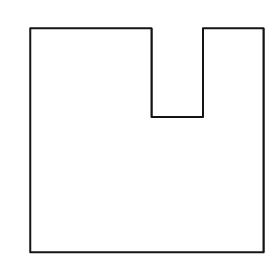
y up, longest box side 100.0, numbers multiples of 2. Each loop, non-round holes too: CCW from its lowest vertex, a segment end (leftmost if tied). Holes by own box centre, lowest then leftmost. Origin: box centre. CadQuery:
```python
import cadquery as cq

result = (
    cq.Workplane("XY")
    .moveTo(-50.0, -48.0)
    .lineTo(50.0, -48.0)
    .lineTo(50.0, 48.0)
    .lineTo(24.0, 48.0)
    .lineTo(24.0, 10.0)
    .lineTo(2.0, 10.0)
    .lineTo(2.0, 48.0)
    .lineTo(-50.0, 48.0)
    .close()
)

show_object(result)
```